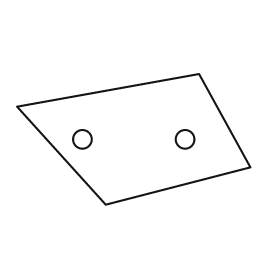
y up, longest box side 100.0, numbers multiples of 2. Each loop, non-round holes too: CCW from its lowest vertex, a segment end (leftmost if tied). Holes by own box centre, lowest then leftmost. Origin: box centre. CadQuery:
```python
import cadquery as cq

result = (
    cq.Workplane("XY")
    .moveTo(-12.0, -28.0)
    .lineTo(50.0, -12.0)
    .lineTo(28.0, 28.0)
    .lineTo(-50.0, 14.0)
    .close()
    .moveTo(-22.0, 0.0)
    .circle(4.0)
    .moveTo(22.0, 0.0)
    .circle(4.0)
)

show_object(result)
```